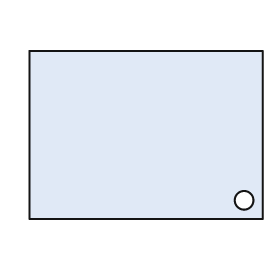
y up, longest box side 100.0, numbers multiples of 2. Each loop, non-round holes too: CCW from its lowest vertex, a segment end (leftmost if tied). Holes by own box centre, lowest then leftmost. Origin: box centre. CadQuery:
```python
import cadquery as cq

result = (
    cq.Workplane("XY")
    .moveTo(-50.0, -36.0)
    .lineTo(50.0, -36.0)
    .lineTo(50.0, 36.0)
    .lineTo(-50.0, 36.0)
    .close()
    .moveTo(42.0, -28.0)
    .circle(4.0)
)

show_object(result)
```